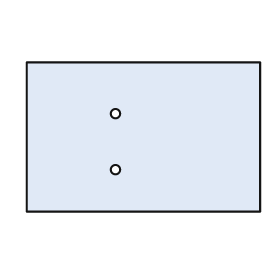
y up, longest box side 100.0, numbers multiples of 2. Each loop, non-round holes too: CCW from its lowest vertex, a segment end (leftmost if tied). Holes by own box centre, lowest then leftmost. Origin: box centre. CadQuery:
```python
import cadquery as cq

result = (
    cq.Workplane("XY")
    .moveTo(-50.0, -32.0)
    .lineTo(50.0, -32.0)
    .lineTo(50.0, 32.0)
    .lineTo(-50.0, 32.0)
    .close()
    .moveTo(-12.0, -14.0)
    .circle(2.0)
    .moveTo(-12.0, 10.0)
    .circle(2.0)
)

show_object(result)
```